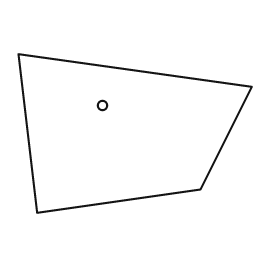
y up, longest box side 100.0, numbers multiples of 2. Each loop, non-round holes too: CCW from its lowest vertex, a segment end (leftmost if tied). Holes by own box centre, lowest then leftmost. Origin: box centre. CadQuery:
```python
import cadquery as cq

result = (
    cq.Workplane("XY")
    .moveTo(-42.0, -34.0)
    .lineTo(28.0, -24.0)
    .lineTo(50.0, 20.0)
    .lineTo(-50.0, 34.0)
    .close()
    .moveTo(-14.0, 12.0)
    .circle(2.0)
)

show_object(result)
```